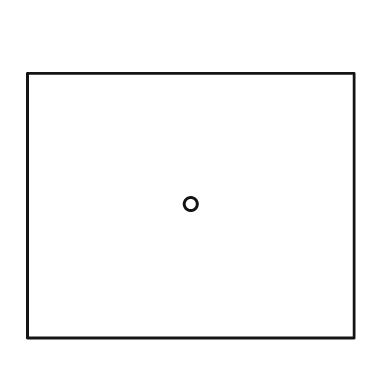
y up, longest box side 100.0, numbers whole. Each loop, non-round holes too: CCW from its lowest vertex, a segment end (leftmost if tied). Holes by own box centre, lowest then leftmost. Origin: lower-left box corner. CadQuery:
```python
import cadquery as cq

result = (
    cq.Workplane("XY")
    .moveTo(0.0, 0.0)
    .lineTo(100.0, 0.0)
    .lineTo(100.0, 81.0)
    .lineTo(0.0, 81.0)
    .close()
    .moveTo(50.0, 41.0)
    .circle(2.0)
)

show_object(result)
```